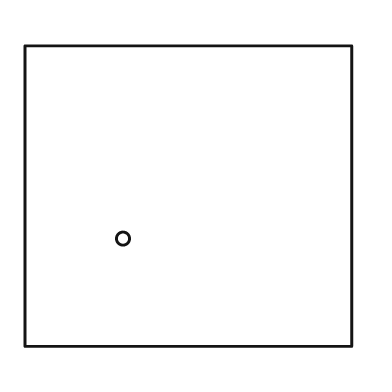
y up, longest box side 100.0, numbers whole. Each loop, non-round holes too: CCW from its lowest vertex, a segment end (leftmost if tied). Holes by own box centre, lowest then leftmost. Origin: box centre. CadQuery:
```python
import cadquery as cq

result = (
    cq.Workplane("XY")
    .moveTo(-50.0, -46.0)
    .lineTo(50.0, -46.0)
    .lineTo(50.0, 46.0)
    .lineTo(-50.0, 46.0)
    .close()
    .moveTo(-20.0, -13.0)
    .circle(2.0)
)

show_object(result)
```